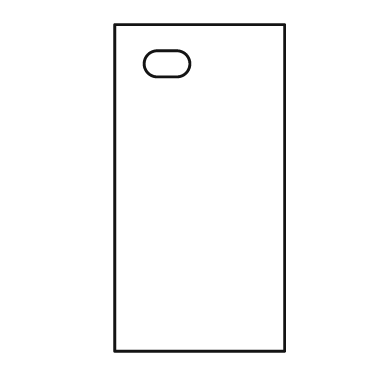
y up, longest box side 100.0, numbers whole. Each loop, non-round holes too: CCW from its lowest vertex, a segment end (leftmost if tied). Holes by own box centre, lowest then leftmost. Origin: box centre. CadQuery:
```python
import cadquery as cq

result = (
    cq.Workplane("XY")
    .moveTo(-26.0, -50.0)
    .lineTo(26.0, -50.0)
    .lineTo(26.0, 50.0)
    .lineTo(-26.0, 50.0)
    .close()
    .moveTo(-13.0, 34.0)
    .lineTo(-7.0, 34.0)
    .threePointArc((-3.0, 38.0), (-7.0, 42.0))
    .lineTo(-13.0, 42.0)
    .threePointArc((-17.0, 38.0), (-13.0, 34.0))
    .close()
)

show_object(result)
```